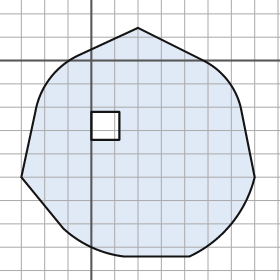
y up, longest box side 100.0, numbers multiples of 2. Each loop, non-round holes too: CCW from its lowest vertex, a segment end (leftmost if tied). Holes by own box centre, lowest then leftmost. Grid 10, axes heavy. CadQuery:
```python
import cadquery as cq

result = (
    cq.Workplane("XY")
    .moveTo(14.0, -84.0)
    .lineTo(42.0, -84.0)
    .threePointArc((60.0, -70.0), (70.0, -50.0))
    .lineTo(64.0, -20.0)
    .threePointArc((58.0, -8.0), (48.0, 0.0))
    .lineTo(20.0, 14.0)
    .lineTo(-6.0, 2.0)
    .threePointArc((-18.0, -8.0), (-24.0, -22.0))
    .lineTo(-30.0, -50.0)
    .lineTo(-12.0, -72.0)
    .threePointArc((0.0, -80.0), (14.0, -84.0))
    .close()
    .moveTo(0.0, -34.0)
    .lineTo(12.0, -34.0)
    .lineTo(12.0, -22.0)
    .lineTo(0.0, -22.0)
    .close()
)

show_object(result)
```